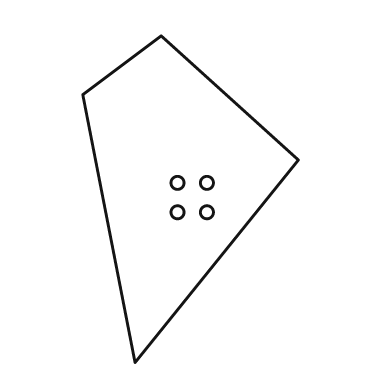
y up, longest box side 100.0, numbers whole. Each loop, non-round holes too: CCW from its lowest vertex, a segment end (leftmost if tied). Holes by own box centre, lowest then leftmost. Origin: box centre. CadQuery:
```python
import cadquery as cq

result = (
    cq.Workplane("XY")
    .moveTo(-17.0, -50.0)
    .lineTo(33.0, 12.0)
    .lineTo(-9.0, 50.0)
    .lineTo(-33.0, 32.0)
    .close()
    .moveTo(-4.0, -4.0)
    .circle(2.0)
    .moveTo(5.0, -4.0)
    .circle(2.0)
    .moveTo(-4.0, 5.0)
    .circle(2.0)
    .moveTo(5.0, 5.0)
    .circle(2.0)
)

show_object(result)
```